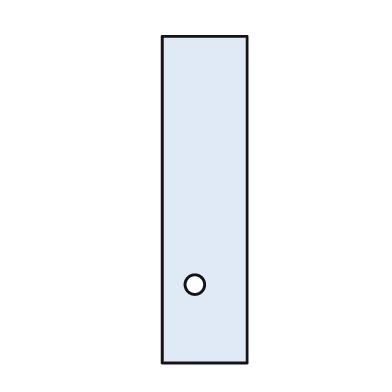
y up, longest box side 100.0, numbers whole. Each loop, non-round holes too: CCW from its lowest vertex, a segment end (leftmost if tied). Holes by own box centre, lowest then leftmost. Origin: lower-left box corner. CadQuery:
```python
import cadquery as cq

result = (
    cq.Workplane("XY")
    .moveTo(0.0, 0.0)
    .lineTo(26.0, 0.0)
    .lineTo(26.0, 100.0)
    .lineTo(0.0, 100.0)
    .close()
    .moveTo(10.0, 24.0)
    .circle(3.0)
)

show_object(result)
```